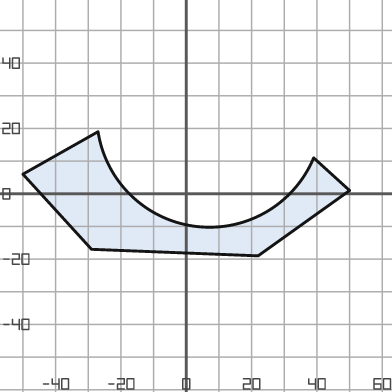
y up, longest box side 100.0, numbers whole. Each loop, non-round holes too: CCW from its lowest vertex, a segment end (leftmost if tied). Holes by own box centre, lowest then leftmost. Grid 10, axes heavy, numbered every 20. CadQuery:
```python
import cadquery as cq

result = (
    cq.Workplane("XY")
    .moveTo(22.0, -19.0)
    .lineTo(50.0, 1.0)
    .lineTo(39.0, 11.0)
    .threePointArc((3.0, -10.0), (-27.0, 19.0))
    .lineTo(-50.0, 6.0)
    .lineTo(-29.0, -17.0)
    .close()
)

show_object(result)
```